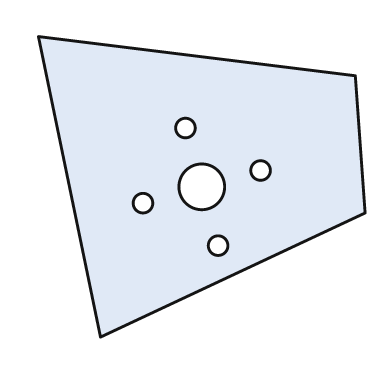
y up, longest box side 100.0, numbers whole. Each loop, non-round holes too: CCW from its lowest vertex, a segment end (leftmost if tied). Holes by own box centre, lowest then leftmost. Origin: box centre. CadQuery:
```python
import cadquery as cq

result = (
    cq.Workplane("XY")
    .moveTo(-31.0, -46.0)
    .lineTo(50.0, -8.0)
    .lineTo(47.0, 34.0)
    .lineTo(-50.0, 46.0)
    .close()
    .moveTo(5.0, -18.0)
    .circle(3.0)
    .moveTo(-18.0, -5.0)
    .circle(3.0)
    .moveTo(0.0, 0.0)
    .circle(7.0)
    .moveTo(18.0, 5.0)
    .circle(3.0)
    .moveTo(-5.0, 18.0)
    .circle(3.0)
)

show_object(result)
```